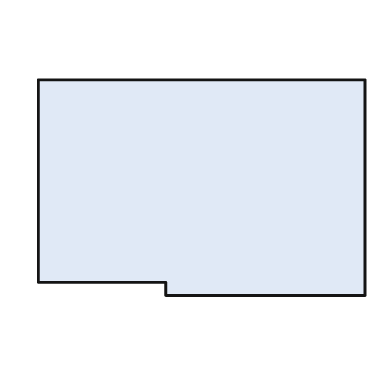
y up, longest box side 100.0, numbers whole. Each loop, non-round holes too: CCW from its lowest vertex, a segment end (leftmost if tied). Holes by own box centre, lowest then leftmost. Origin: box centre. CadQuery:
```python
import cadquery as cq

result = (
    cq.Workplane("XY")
    .moveTo(-11.0, -33.0)
    .lineTo(50.0, -33.0)
    .lineTo(50.0, 33.0)
    .lineTo(-50.0, 33.0)
    .lineTo(-50.0, -29.0)
    .lineTo(-11.0, -29.0)
    .close()
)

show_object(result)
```